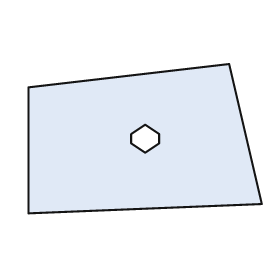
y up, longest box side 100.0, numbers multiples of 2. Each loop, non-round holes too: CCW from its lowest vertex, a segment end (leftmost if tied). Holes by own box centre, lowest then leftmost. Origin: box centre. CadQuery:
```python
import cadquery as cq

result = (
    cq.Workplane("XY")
    .moveTo(-50.0, -32.0)
    .lineTo(50.0, -28.0)
    .lineTo(36.0, 32.0)
    .lineTo(-50.0, 22.0)
    .close()
    .moveTo(0.0, -6.0)
    .lineTo(6.0, -2.0)
    .lineTo(6.0, 2.0)
    .lineTo(0.0, 6.0)
    .lineTo(-6.0, 2.0)
    .lineTo(-6.0, -2.0)
    .close()
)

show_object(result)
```